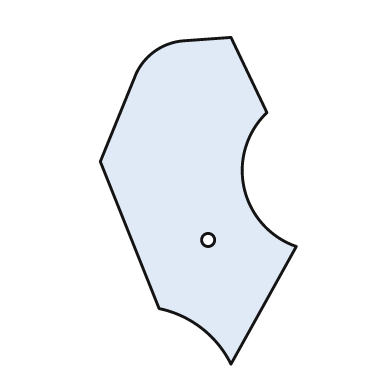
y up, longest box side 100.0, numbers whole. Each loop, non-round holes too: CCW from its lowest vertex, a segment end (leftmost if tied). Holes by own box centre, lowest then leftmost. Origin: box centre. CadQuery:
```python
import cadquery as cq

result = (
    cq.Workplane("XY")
    .moveTo(10.0, -50.0)
    .lineTo(30.0, -14.0)
    .threePointArc((14.0, 4.0), (21.0, 27.0))
    .lineTo(10.0, 50.0)
    .lineTo(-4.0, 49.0)
    .threePointArc((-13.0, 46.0), (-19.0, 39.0))
    .lineTo(-30.0, 12.0)
    .lineTo(-12.0, -33.0)
    .threePointArc((1.0, -39.0), (10.0, -50.0))
    .close()
    .moveTo(3.0, -12.0)
    .circle(2.0)
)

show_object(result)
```